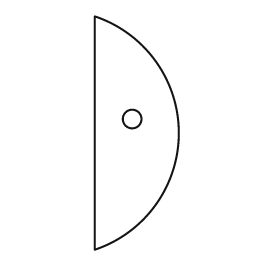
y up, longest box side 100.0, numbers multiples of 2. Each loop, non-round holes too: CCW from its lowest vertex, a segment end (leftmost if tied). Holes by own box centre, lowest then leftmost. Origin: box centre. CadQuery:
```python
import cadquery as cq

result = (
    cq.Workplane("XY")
    .moveTo(-18.0, -50.0)
    .threePointArc((18.0, 0.0), (-18.0, 50.0))
    .close()
    .moveTo(-2.0, 6.0)
    .circle(4.0)
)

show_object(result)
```